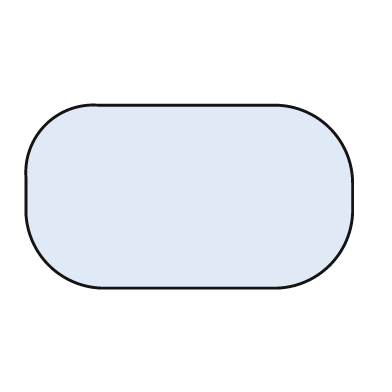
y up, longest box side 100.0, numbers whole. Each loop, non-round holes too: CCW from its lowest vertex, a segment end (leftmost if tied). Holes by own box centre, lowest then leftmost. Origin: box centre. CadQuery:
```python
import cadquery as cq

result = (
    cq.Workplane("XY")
    .moveTo(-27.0, -28.0)
    .lineTo(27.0, -28.0)
    .threePointArc((43.0, -21.0), (50.0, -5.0))
    .lineTo(50.0, 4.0)
    .threePointArc((43.0, 21.0), (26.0, 28.0))
    .lineTo(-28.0, 28.0)
    .threePointArc((-44.0, 22.0), (-50.0, 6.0))
    .lineTo(-50.0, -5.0)
    .threePointArc((-43.0, -21.0), (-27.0, -28.0))
    .close()
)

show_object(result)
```